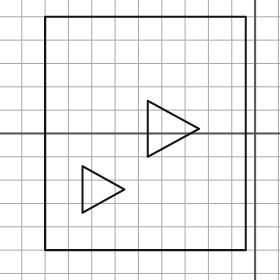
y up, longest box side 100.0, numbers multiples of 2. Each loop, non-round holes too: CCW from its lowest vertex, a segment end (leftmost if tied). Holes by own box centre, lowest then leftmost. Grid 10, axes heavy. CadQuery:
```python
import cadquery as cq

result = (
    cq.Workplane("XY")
    .moveTo(-90.0, -50.0)
    .lineTo(-4.0, -50.0)
    .lineTo(-4.0, 50.0)
    .lineTo(-90.0, 50.0)
    .close()
    .moveTo(-74.0, -34.0)
    .lineTo(-56.0, -24.0)
    .lineTo(-74.0, -14.0)
    .close()
    .moveTo(-46.0, -10.0)
    .lineTo(-24.0, 2.0)
    .lineTo(-46.0, 14.0)
    .close()
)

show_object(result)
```